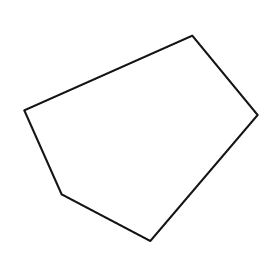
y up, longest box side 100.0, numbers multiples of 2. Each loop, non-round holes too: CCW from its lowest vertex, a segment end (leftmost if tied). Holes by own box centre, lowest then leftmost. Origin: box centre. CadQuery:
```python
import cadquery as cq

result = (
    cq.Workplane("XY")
    .moveTo(4.0, -44.0)
    .lineTo(50.0, 10.0)
    .lineTo(22.0, 44.0)
    .lineTo(-50.0, 12.0)
    .lineTo(-34.0, -24.0)
    .close()
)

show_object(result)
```